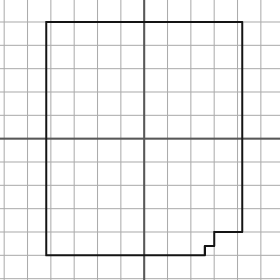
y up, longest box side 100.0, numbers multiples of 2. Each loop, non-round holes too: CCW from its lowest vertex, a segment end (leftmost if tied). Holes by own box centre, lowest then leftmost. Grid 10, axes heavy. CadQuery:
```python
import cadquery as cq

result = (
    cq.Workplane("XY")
    .moveTo(-42.0, -50.0)
    .lineTo(26.0, -50.0)
    .lineTo(26.0, -46.0)
    .lineTo(30.0, -46.0)
    .lineTo(30.0, -40.0)
    .lineTo(42.0, -40.0)
    .lineTo(42.0, 50.0)
    .lineTo(-42.0, 50.0)
    .close()
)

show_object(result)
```